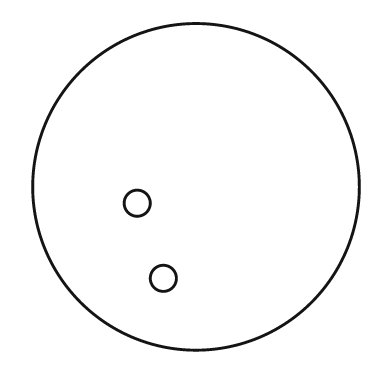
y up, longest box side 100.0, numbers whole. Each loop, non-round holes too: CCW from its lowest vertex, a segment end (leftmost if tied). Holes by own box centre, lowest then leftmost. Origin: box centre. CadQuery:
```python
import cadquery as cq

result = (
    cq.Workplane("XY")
    .moveTo(0.0, 0.0)
    .circle(50.0)
    .moveTo(-10.0, -28.0)
    .circle(4.0)
    .moveTo(-18.0, -5.0)
    .circle(4.0)
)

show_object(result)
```